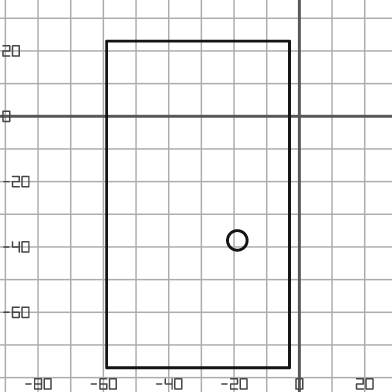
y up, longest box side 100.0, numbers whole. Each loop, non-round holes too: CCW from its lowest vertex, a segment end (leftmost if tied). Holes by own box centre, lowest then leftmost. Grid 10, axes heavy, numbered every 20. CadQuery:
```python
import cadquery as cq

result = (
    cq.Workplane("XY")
    .moveTo(-59.0, -77.0)
    .lineTo(-3.0, -77.0)
    .lineTo(-3.0, 23.0)
    .lineTo(-59.0, 23.0)
    .close()
    .moveTo(-19.0, -38.0)
    .circle(3.0)
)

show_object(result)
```